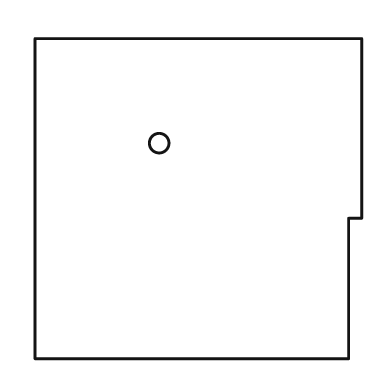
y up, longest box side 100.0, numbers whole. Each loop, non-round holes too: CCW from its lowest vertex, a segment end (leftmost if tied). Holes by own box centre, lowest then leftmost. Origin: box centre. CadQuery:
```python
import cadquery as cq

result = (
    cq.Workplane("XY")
    .moveTo(-50.0, -49.0)
    .lineTo(46.0, -49.0)
    .lineTo(46.0, -6.0)
    .lineTo(50.0, -6.0)
    .lineTo(50.0, 49.0)
    .lineTo(-50.0, 49.0)
    .close()
    .moveTo(-12.0, 17.0)
    .circle(3.0)
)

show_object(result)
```